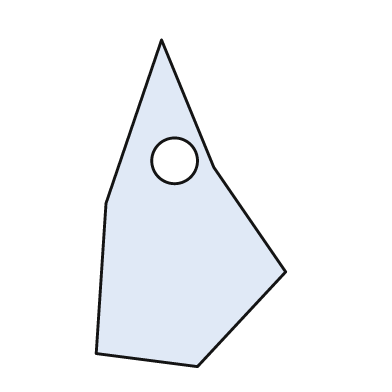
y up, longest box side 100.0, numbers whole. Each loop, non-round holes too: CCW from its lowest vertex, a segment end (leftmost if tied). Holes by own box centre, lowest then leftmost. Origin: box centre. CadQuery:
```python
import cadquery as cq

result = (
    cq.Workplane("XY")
    .moveTo(2.0, -50.0)
    .lineTo(29.0, -21.0)
    .lineTo(7.0, 11.0)
    .lineTo(-9.0, 50.0)
    .lineTo(-26.0, 0.0)
    .lineTo(-29.0, -46.0)
    .close()
    .moveTo(-5.0, 13.0)
    .circle(7.0)
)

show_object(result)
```